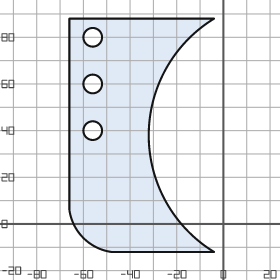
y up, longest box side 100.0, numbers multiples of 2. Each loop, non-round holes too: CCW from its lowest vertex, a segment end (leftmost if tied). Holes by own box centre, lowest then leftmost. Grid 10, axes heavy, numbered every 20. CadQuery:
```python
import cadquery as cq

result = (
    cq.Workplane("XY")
    .moveTo(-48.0, -12.0)
    .lineTo(-4.0, -12.0)
    .threePointArc((-32.0, 38.0), (-4.0, 88.0))
    .lineTo(-66.0, 88.0)
    .lineTo(-66.0, 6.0)
    .threePointArc((-60.0, -6.0), (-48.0, -12.0))
    .close()
    .moveTo(-56.0, 40.0)
    .circle(4.0)
    .moveTo(-56.0, 60.0)
    .circle(4.0)
    .moveTo(-56.0, 80.0)
    .circle(4.0)
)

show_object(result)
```